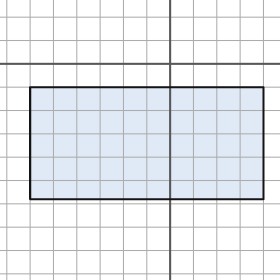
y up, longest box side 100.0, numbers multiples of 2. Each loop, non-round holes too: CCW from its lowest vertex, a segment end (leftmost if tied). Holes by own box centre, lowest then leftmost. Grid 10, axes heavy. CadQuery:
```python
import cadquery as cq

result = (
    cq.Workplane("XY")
    .moveTo(-60.0, -58.0)
    .lineTo(40.0, -58.0)
    .lineTo(40.0, -10.0)
    .lineTo(-60.0, -10.0)
    .close()
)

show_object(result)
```